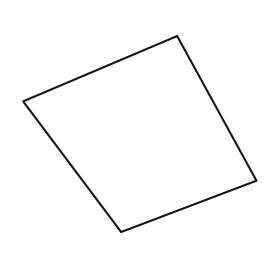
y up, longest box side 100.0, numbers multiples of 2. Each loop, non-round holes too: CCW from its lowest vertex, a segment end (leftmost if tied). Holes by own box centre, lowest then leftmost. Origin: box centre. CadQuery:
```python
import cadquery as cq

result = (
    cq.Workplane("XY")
    .moveTo(-8.0, -42.0)
    .lineTo(50.0, -20.0)
    .lineTo(16.0, 42.0)
    .lineTo(-50.0, 14.0)
    .close()
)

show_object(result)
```